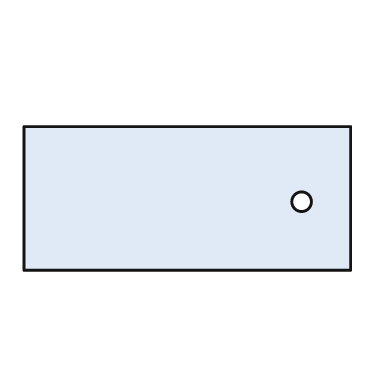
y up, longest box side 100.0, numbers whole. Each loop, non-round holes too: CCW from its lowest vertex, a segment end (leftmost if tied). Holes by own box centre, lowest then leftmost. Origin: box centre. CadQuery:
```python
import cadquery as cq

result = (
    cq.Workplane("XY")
    .moveTo(-50.0, -22.0)
    .lineTo(50.0, -22.0)
    .lineTo(50.0, 22.0)
    .lineTo(-50.0, 22.0)
    .close()
    .moveTo(35.0, -1.0)
    .circle(3.0)
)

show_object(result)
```